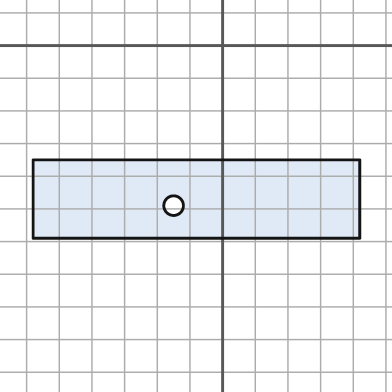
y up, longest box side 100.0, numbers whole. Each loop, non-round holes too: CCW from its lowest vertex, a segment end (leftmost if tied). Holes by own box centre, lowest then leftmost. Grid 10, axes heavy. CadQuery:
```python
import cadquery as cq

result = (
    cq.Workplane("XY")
    .moveTo(-58.0, -59.0)
    .lineTo(42.0, -59.0)
    .lineTo(42.0, -35.0)
    .lineTo(-58.0, -35.0)
    .close()
    .moveTo(-15.0, -49.0)
    .circle(3.0)
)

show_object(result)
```